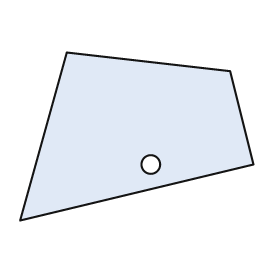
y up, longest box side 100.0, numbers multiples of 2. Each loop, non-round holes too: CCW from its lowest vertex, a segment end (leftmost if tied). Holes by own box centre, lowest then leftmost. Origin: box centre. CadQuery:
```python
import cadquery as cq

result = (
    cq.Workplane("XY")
    .moveTo(-50.0, -36.0)
    .lineTo(50.0, -12.0)
    .lineTo(40.0, 28.0)
    .lineTo(-30.0, 36.0)
    .close()
    .moveTo(6.0, -12.0)
    .circle(4.0)
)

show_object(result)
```